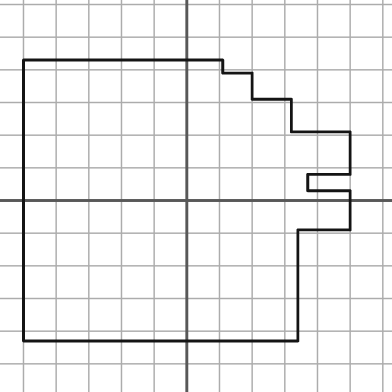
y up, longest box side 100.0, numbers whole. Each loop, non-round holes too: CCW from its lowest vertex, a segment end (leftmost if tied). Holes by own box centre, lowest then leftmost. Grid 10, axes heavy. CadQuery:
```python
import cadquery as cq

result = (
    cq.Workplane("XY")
    .moveTo(-50.0, -43.0)
    .lineTo(34.0, -43.0)
    .lineTo(34.0, -9.0)
    .lineTo(50.0, -9.0)
    .lineTo(50.0, 3.0)
    .lineTo(37.0, 3.0)
    .lineTo(37.0, 8.0)
    .lineTo(50.0, 8.0)
    .lineTo(50.0, 21.0)
    .lineTo(32.0, 21.0)
    .lineTo(32.0, 31.0)
    .lineTo(20.0, 31.0)
    .lineTo(20.0, 39.0)
    .lineTo(11.0, 39.0)
    .lineTo(11.0, 43.0)
    .lineTo(-50.0, 43.0)
    .close()
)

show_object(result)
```